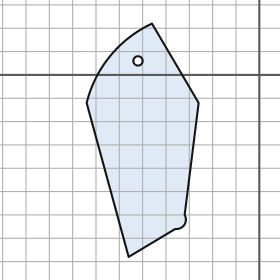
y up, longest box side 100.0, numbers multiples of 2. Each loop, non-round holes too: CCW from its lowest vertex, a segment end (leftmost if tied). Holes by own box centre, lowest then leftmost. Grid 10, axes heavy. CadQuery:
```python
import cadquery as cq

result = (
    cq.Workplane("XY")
    .moveTo(-56.0, -78.0)
    .lineTo(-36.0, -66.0)
    .threePointArc((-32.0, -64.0), (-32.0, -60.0))
    .lineTo(-26.0, -12.0)
    .lineTo(-46.0, 22.0)
    .threePointArc((-64.0, 8.0), (-74.0, -12.0))
    .close()
    .moveTo(-52.0, 6.0)
    .circle(2.0)
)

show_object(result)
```